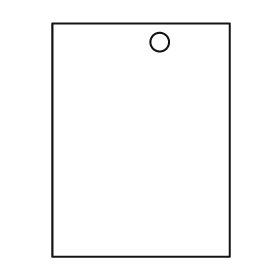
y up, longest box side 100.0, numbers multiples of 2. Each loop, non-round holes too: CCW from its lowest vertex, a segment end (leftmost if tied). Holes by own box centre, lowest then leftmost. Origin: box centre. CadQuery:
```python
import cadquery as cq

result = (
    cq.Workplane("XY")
    .moveTo(-38.0, -50.0)
    .lineTo(38.0, -50.0)
    .lineTo(38.0, 50.0)
    .lineTo(-38.0, 50.0)
    .close()
    .moveTo(8.0, 42.0)
    .circle(4.0)
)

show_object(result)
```